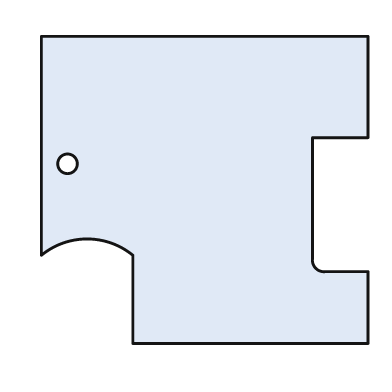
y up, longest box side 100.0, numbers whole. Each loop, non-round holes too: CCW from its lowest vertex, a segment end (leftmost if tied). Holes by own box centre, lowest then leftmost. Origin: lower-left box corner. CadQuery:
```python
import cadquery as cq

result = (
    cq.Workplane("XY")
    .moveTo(28.0, 0.0)
    .lineTo(100.0, 0.0)
    .lineTo(100.0, 22.0)
    .lineTo(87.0, 22.0)
    .threePointArc((84.0, 23.0), (83.0, 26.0))
    .lineTo(83.0, 63.0)
    .lineTo(100.0, 63.0)
    .lineTo(100.0, 94.0)
    .lineTo(0.0, 94.0)
    .lineTo(0.0, 27.0)
    .threePointArc((14.0, 32.0), (28.0, 27.0))
    .close()
    .moveTo(8.0, 55.0)
    .circle(3.0)
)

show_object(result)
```